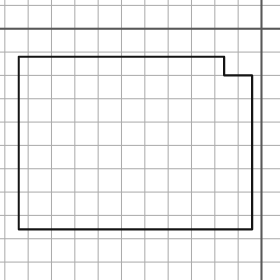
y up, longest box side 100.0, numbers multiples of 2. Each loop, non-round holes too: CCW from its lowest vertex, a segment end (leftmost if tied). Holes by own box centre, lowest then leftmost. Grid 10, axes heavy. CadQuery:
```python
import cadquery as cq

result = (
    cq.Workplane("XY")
    .moveTo(-104.0, -86.0)
    .lineTo(-4.0, -86.0)
    .lineTo(-4.0, -20.0)
    .lineTo(-16.0, -20.0)
    .lineTo(-16.0, -12.0)
    .lineTo(-104.0, -12.0)
    .close()
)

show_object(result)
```